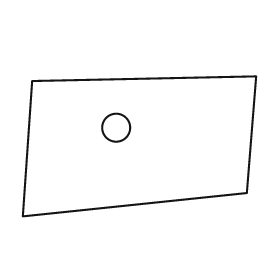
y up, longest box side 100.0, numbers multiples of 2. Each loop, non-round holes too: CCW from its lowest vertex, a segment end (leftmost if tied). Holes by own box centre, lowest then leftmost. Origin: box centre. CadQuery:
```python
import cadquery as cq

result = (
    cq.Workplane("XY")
    .moveTo(-50.0, -30.0)
    .lineTo(46.0, -20.0)
    .lineTo(50.0, 30.0)
    .lineTo(-46.0, 28.0)
    .close()
    .moveTo(-10.0, 8.0)
    .circle(6.0)
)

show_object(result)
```